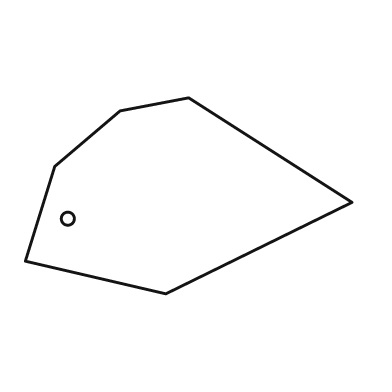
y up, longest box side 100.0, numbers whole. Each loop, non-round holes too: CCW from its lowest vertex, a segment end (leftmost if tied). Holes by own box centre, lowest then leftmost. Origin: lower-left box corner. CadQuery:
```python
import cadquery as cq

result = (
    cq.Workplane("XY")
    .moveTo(43.0, 0.0)
    .lineTo(100.0, 28.0)
    .lineTo(50.0, 60.0)
    .lineTo(29.0, 56.0)
    .lineTo(9.0, 39.0)
    .lineTo(0.0, 10.0)
    .close()
    .moveTo(13.0, 23.0)
    .circle(2.0)
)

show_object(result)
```